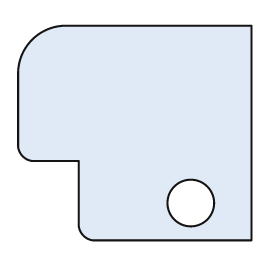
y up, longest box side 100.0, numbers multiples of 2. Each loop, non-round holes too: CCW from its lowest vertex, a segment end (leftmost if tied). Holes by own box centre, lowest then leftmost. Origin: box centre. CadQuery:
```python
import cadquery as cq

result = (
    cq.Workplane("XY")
    .moveTo(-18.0, -46.0)
    .lineTo(50.0, -46.0)
    .lineTo(50.0, 46.0)
    .lineTo(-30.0, 46.0)
    .threePointArc((-44.0, 40.0), (-50.0, 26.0))
    .lineTo(-50.0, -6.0)
    .threePointArc((-48.0, -10.0), (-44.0, -12.0))
    .lineTo(-24.0, -12.0)
    .lineTo(-24.0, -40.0)
    .threePointArc((-22.0, -44.0), (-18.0, -46.0))
    .close()
    .moveTo(24.0, -30.0)
    .circle(10.0)
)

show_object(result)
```